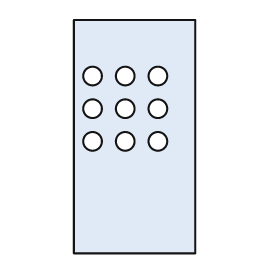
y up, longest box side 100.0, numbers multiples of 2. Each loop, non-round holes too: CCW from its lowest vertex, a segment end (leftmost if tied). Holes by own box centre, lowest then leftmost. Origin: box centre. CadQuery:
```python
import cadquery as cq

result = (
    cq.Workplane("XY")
    .moveTo(-26.0, -50.0)
    .lineTo(26.0, -50.0)
    .lineTo(26.0, 50.0)
    .lineTo(-26.0, 50.0)
    .close()
    .moveTo(-18.0, -2.0)
    .circle(4.0)
    .moveTo(-4.0, -2.0)
    .circle(4.0)
    .moveTo(10.0, -2.0)
    .circle(4.0)
    .moveTo(-18.0, 12.0)
    .circle(4.0)
    .moveTo(-4.0, 12.0)
    .circle(4.0)
    .moveTo(10.0, 12.0)
    .circle(4.0)
    .moveTo(-18.0, 26.0)
    .circle(4.0)
    .moveTo(-4.0, 26.0)
    .circle(4.0)
    .moveTo(10.0, 26.0)
    .circle(4.0)
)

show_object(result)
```